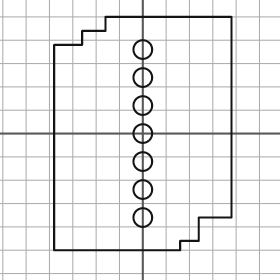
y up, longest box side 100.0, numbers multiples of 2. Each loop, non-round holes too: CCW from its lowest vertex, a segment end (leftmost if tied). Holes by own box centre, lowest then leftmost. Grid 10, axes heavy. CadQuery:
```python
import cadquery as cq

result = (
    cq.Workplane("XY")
    .moveTo(-38.0, -50.0)
    .lineTo(16.0, -50.0)
    .lineTo(16.0, -46.0)
    .lineTo(24.0, -46.0)
    .lineTo(24.0, -36.0)
    .lineTo(38.0, -36.0)
    .lineTo(38.0, 50.0)
    .lineTo(-16.0, 50.0)
    .lineTo(-16.0, 44.0)
    .lineTo(-26.0, 44.0)
    .lineTo(-26.0, 38.0)
    .lineTo(-38.0, 38.0)
    .close()
    .moveTo(0.0, -36.0)
    .circle(4.0)
    .moveTo(0.0, -24.0)
    .circle(4.0)
    .moveTo(0.0, -12.0)
    .circle(4.0)
    .moveTo(0.0, 0.0)
    .circle(4.0)
    .moveTo(0.0, 12.0)
    .circle(4.0)
    .moveTo(0.0, 24.0)
    .circle(4.0)
    .moveTo(0.0, 36.0)
    .circle(4.0)
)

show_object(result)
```